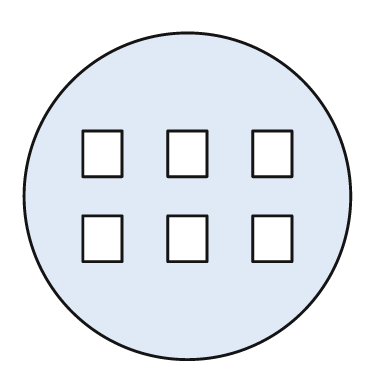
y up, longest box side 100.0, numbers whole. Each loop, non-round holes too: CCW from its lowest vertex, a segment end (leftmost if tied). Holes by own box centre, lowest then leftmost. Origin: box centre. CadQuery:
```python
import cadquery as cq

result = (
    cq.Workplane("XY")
    .moveTo(0.0, 0.0)
    .circle(50.0)
    .moveTo(-32.0, -20.0)
    .lineTo(-20.0, -20.0)
    .lineTo(-20.0, -6.0)
    .lineTo(-32.0, -6.0)
    .close()
    .moveTo(-6.0, -20.0)
    .lineTo(6.0, -20.0)
    .lineTo(6.0, -6.0)
    .lineTo(-6.0, -6.0)
    .close()
    .moveTo(20.0, -20.0)
    .lineTo(32.0, -20.0)
    .lineTo(32.0, -6.0)
    .lineTo(20.0, -6.0)
    .close()
    .moveTo(-32.0, 6.0)
    .lineTo(-20.0, 6.0)
    .lineTo(-20.0, 20.0)
    .lineTo(-32.0, 20.0)
    .close()
    .moveTo(-6.0, 6.0)
    .lineTo(6.0, 6.0)
    .lineTo(6.0, 20.0)
    .lineTo(-6.0, 20.0)
    .close()
    .moveTo(20.0, 6.0)
    .lineTo(32.0, 6.0)
    .lineTo(32.0, 20.0)
    .lineTo(20.0, 20.0)
    .close()
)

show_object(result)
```